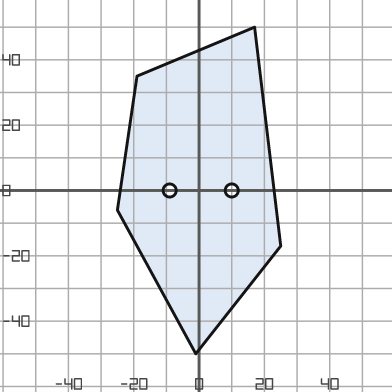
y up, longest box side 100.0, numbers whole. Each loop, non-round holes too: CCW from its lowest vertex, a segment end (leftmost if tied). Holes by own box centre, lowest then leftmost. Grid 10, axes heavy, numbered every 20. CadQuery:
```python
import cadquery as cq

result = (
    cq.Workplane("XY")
    .moveTo(-1.0, -50.0)
    .lineTo(25.0, -17.0)
    .lineTo(17.0, 50.0)
    .lineTo(-19.0, 35.0)
    .lineTo(-25.0, -6.0)
    .close()
    .moveTo(-9.0, 0.0)
    .circle(2.0)
    .moveTo(10.0, 0.0)
    .circle(2.0)
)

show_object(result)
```